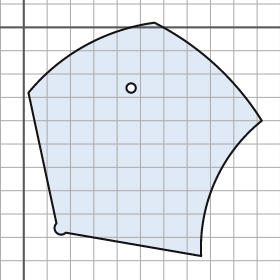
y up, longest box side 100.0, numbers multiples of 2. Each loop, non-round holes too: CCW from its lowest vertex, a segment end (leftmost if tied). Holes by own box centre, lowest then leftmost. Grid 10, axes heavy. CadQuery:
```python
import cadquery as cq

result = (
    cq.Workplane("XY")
    .moveTo(76.0, -98.0)
    .threePointArc((82.0, -66.0), (102.0, -40.0))
    .threePointArc((82.0, -16.0), (56.0, 2.0))
    .threePointArc((26.0, -8.0), (2.0, -28.0))
    .lineTo(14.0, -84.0)
    .threePointArc((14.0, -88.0), (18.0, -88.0))
    .close()
    .moveTo(46.0, -26.0)
    .circle(2.0)
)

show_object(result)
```